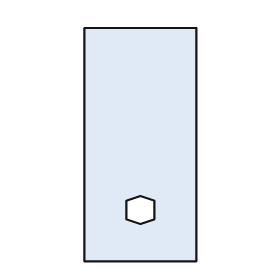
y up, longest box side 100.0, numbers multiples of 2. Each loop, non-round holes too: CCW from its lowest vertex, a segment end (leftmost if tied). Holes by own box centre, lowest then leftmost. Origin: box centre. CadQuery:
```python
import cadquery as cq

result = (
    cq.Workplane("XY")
    .moveTo(-24.0, -50.0)
    .lineTo(24.0, -50.0)
    .lineTo(24.0, 50.0)
    .lineTo(-24.0, 50.0)
    .close()
    .moveTo(0.0, -34.0)
    .lineTo(6.0, -32.0)
    .lineTo(6.0, -24.0)
    .lineTo(0.0, -22.0)
    .lineTo(-6.0, -24.0)
    .lineTo(-6.0, -32.0)
    .close()
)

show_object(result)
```